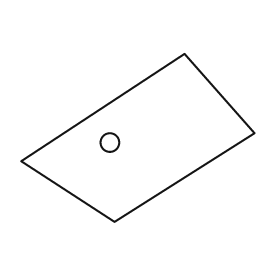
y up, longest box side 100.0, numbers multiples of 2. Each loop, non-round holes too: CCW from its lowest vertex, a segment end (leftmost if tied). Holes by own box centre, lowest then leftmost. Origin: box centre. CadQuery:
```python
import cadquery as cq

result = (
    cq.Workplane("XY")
    .moveTo(-10.0, -36.0)
    .lineTo(50.0, 2.0)
    .lineTo(20.0, 36.0)
    .lineTo(-50.0, -10.0)
    .close()
    .moveTo(-12.0, -2.0)
    .circle(4.0)
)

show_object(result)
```